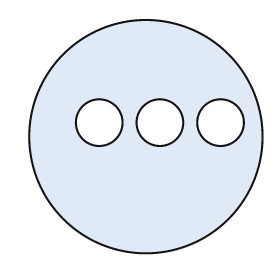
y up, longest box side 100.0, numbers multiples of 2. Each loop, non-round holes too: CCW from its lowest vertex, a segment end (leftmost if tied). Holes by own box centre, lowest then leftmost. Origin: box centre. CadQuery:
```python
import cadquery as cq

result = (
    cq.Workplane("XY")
    .moveTo(0.0, 0.0)
    .circle(50.0)
    .moveTo(-20.0, 6.0)
    .circle(10.0)
    .moveTo(6.0, 6.0)
    .circle(10.0)
    .moveTo(32.0, 6.0)
    .circle(10.0)
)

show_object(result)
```